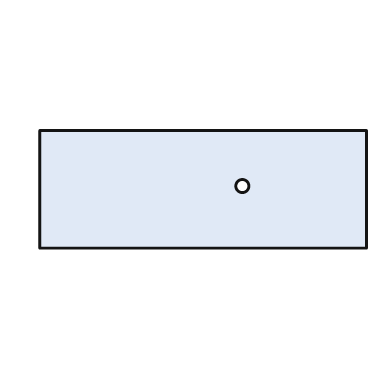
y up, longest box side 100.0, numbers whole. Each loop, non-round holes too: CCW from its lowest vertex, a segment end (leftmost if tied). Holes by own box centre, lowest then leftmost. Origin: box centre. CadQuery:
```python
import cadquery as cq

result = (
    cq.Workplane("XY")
    .moveTo(-50.0, -18.0)
    .lineTo(50.0, -18.0)
    .lineTo(50.0, 18.0)
    .lineTo(-50.0, 18.0)
    .close()
    .moveTo(12.0, 1.0)
    .circle(2.0)
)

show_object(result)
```